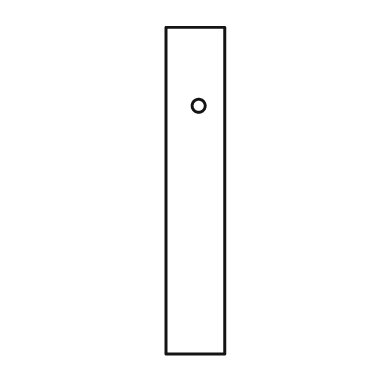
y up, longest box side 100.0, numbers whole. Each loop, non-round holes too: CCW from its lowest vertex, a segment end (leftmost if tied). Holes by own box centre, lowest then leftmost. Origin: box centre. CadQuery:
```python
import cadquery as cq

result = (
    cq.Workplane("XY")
    .moveTo(-9.0, -50.0)
    .lineTo(9.0, -50.0)
    .lineTo(9.0, 50.0)
    .lineTo(-9.0, 50.0)
    .close()
    .moveTo(1.0, 26.0)
    .circle(2.0)
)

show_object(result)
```